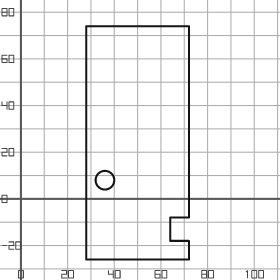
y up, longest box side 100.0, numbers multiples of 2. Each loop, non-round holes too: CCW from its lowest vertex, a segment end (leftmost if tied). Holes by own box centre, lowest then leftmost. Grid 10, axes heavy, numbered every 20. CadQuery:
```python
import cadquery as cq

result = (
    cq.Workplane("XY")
    .moveTo(28.0, -26.0)
    .lineTo(72.0, -26.0)
    .lineTo(72.0, -18.0)
    .lineTo(64.0, -18.0)
    .lineTo(64.0, -8.0)
    .lineTo(72.0, -8.0)
    .lineTo(72.0, 74.0)
    .lineTo(28.0, 74.0)
    .close()
    .moveTo(36.0, 8.0)
    .circle(4.0)
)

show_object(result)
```